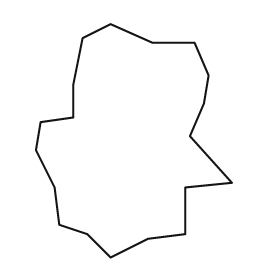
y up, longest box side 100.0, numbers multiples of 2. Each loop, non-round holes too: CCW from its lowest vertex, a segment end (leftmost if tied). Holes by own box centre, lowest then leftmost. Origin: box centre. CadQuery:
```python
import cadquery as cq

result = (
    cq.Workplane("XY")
    .moveTo(-10.0, -50.0)
    .lineTo(6.0, -42.0)
    .lineTo(22.0, -40.0)
    .lineTo(22.0, -20.0)
    .lineTo(42.0, -18.0)
    .lineTo(24.0, 2.0)
    .lineTo(30.0, 16.0)
    .lineTo(32.0, 28.0)
    .lineTo(26.0, 42.0)
    .lineTo(8.0, 42.0)
    .lineTo(-10.0, 50.0)
    .lineTo(-22.0, 44.0)
    .lineTo(-26.0, 24.0)
    .lineTo(-26.0, 10.0)
    .lineTo(-40.0, 8.0)
    .lineTo(-42.0, -4.0)
    .lineTo(-34.0, -20.0)
    .lineTo(-32.0, -36.0)
    .lineTo(-20.0, -40.0)
    .close()
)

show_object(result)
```